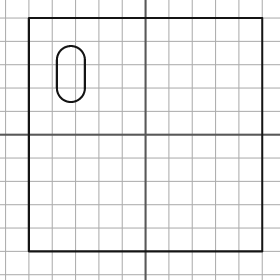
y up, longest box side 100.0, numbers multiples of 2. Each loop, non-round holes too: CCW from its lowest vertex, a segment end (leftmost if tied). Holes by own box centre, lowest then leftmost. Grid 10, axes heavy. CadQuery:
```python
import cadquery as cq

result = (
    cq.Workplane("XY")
    .moveTo(-50.0, -50.0)
    .lineTo(50.0, -50.0)
    .lineTo(50.0, 50.0)
    .lineTo(-50.0, 50.0)
    .close()
    .moveTo(-38.0, 20.0)
    .threePointArc((-32.0, 14.0), (-26.0, 20.0))
    .lineTo(-26.0, 32.0)
    .threePointArc((-32.0, 38.0), (-38.0, 32.0))
    .close()
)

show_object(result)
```